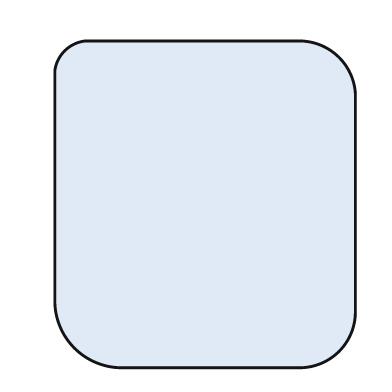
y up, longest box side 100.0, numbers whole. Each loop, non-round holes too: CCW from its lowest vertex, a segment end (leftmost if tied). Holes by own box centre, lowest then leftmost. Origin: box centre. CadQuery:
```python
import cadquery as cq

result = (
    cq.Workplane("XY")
    .moveTo(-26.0, -50.0)
    .lineTo(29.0, -50.0)
    .threePointArc((41.0, -45.0), (46.0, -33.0))
    .lineTo(46.0, 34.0)
    .threePointArc((41.0, 45.0), (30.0, 50.0))
    .lineTo(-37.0, 50.0)
    .threePointArc((-43.0, 47.0), (-46.0, 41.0))
    .lineTo(-46.0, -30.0)
    .threePointArc((-40.0, -44.0), (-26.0, -50.0))
    .close()
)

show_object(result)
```